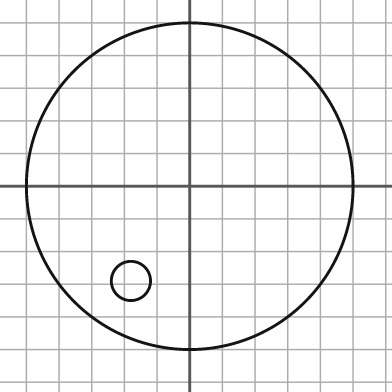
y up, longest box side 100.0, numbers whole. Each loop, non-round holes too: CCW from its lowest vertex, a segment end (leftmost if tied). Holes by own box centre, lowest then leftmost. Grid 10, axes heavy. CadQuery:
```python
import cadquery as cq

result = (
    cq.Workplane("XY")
    .moveTo(0.0, 0.0)
    .circle(50.0)
    .moveTo(-18.0, -29.0)
    .circle(6.0)
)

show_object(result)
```